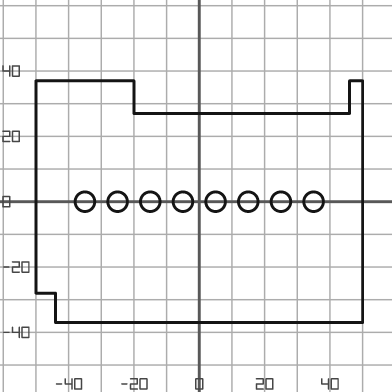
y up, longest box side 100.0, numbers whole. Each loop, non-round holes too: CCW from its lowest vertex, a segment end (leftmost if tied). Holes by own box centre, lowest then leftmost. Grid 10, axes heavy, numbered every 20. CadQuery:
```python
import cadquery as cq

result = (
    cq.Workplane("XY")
    .moveTo(-44.0, -37.0)
    .lineTo(50.0, -37.0)
    .lineTo(50.0, 37.0)
    .lineTo(46.0, 37.0)
    .lineTo(46.0, 27.0)
    .lineTo(-20.0, 27.0)
    .lineTo(-20.0, 37.0)
    .lineTo(-50.0, 37.0)
    .lineTo(-50.0, -28.0)
    .lineTo(-44.0, -28.0)
    .close()
    .moveTo(-35.0, 0.0)
    .circle(3.0)
    .moveTo(-25.0, 0.0)
    .circle(3.0)
    .moveTo(-15.0, 0.0)
    .circle(3.0)
    .moveTo(-5.0, 0.0)
    .circle(3.0)
    .moveTo(5.0, 0.0)
    .circle(3.0)
    .moveTo(15.0, 0.0)
    .circle(3.0)
    .moveTo(25.0, 0.0)
    .circle(3.0)
    .moveTo(35.0, 0.0)
    .circle(3.0)
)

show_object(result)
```